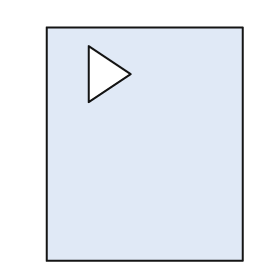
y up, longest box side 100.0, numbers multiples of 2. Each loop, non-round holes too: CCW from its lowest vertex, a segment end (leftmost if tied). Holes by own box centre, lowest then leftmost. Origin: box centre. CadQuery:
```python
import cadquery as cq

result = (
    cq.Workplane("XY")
    .moveTo(-42.0, -50.0)
    .lineTo(42.0, -50.0)
    .lineTo(42.0, 50.0)
    .lineTo(-42.0, 50.0)
    .close()
    .moveTo(-24.0, 18.0)
    .lineTo(-6.0, 30.0)
    .lineTo(-24.0, 42.0)
    .close()
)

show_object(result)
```